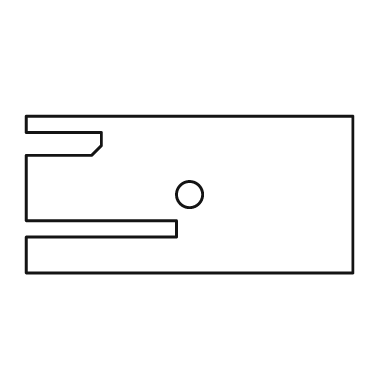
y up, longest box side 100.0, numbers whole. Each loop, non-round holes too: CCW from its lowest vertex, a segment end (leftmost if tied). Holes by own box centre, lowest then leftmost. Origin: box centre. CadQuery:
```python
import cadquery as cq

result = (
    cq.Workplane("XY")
    .moveTo(-50.0, -24.0)
    .lineTo(50.0, -24.0)
    .lineTo(50.0, 24.0)
    .lineTo(-50.0, 24.0)
    .lineTo(-50.0, 19.0)
    .lineTo(-27.0, 19.0)
    .lineTo(-27.0, 15.0)
    .lineTo(-30.0, 12.0)
    .lineTo(-50.0, 12.0)
    .lineTo(-50.0, -8.0)
    .lineTo(-4.0, -8.0)
    .lineTo(-4.0, -13.0)
    .lineTo(-50.0, -13.0)
    .close()
    .moveTo(0.0, 0.0)
    .circle(4.0)
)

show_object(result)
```